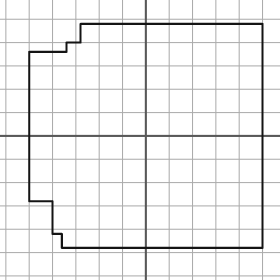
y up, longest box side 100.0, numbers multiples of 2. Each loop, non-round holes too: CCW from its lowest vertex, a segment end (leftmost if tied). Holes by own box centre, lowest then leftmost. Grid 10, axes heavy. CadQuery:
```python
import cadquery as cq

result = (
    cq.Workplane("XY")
    .moveTo(-36.0, -48.0)
    .lineTo(50.0, -48.0)
    .lineTo(50.0, 48.0)
    .lineTo(-28.0, 48.0)
    .lineTo(-28.0, 40.0)
    .lineTo(-34.0, 40.0)
    .lineTo(-34.0, 36.0)
    .lineTo(-50.0, 36.0)
    .lineTo(-50.0, -28.0)
    .lineTo(-40.0, -28.0)
    .lineTo(-40.0, -42.0)
    .lineTo(-36.0, -42.0)
    .close()
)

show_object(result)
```